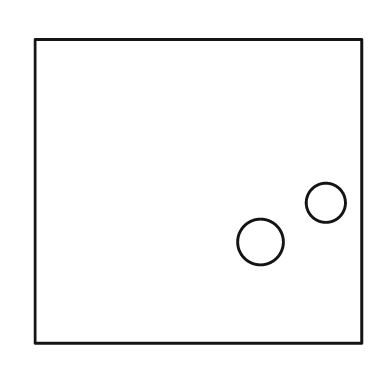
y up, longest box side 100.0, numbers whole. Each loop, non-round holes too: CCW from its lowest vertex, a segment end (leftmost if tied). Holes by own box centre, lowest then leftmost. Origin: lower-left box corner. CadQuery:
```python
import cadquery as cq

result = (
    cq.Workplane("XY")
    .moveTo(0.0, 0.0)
    .lineTo(100.0, 0.0)
    .lineTo(100.0, 93.0)
    .lineTo(0.0, 93.0)
    .close()
    .moveTo(69.0, 31.0)
    .circle(7.0)
    .moveTo(89.0, 43.0)
    .circle(6.0)
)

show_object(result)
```